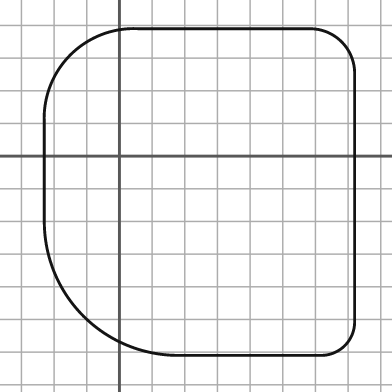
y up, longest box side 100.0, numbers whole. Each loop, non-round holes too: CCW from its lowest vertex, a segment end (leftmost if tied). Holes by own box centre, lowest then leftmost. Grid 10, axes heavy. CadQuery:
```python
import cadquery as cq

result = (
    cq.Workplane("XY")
    .moveTo(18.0, -61.0)
    .lineTo(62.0, -61.0)
    .threePointArc((69.0, -58.0), (72.0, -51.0))
    .lineTo(72.0, 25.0)
    .threePointArc((68.0, 35.0), (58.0, 39.0))
    .lineTo(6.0, 39.0)
    .threePointArc((-15.0, 31.0), (-23.0, 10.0))
    .lineTo(-23.0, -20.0)
    .threePointArc((-11.0, -49.0), (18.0, -61.0))
    .close()
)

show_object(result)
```